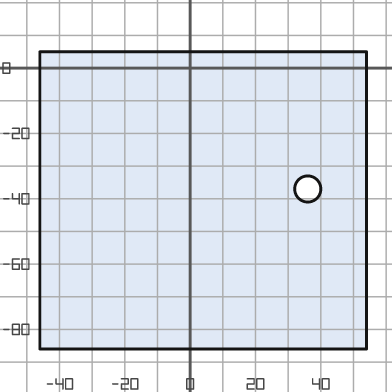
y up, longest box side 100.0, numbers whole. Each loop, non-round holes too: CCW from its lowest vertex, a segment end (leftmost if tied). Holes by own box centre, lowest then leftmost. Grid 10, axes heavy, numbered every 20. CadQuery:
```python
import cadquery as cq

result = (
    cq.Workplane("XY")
    .moveTo(-46.0, -86.0)
    .lineTo(54.0, -86.0)
    .lineTo(54.0, 5.0)
    .lineTo(-46.0, 5.0)
    .close()
    .moveTo(36.0, -37.0)
    .circle(4.0)
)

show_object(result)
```